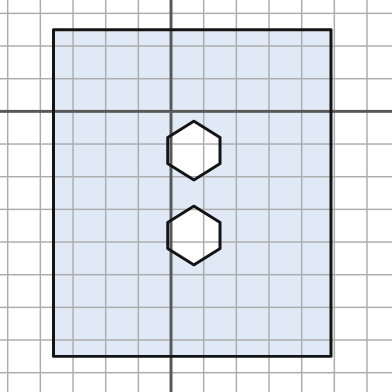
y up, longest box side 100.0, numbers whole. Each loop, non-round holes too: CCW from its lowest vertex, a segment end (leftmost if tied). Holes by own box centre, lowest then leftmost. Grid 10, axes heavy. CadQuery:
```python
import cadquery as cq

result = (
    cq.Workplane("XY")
    .moveTo(-36.0, -75.0)
    .lineTo(49.0, -75.0)
    .lineTo(49.0, 25.0)
    .lineTo(-36.0, 25.0)
    .close()
    .moveTo(7.0, -47.0)
    .lineTo(15.0, -42.0)
    .lineTo(15.0, -34.0)
    .lineTo(7.0, -29.0)
    .lineTo(-1.0, -34.0)
    .lineTo(-1.0, -42.0)
    .close()
    .moveTo(7.0, -21.0)
    .lineTo(15.0, -16.0)
    .lineTo(15.0, -8.0)
    .lineTo(7.0, -3.0)
    .lineTo(-1.0, -8.0)
    .lineTo(-1.0, -16.0)
    .close()
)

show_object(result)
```